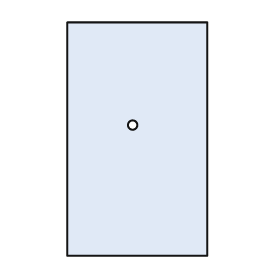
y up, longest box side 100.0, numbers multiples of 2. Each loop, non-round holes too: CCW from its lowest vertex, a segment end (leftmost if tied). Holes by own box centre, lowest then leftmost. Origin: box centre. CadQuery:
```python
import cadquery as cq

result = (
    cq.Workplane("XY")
    .moveTo(-30.0, -50.0)
    .lineTo(30.0, -50.0)
    .lineTo(30.0, 50.0)
    .lineTo(-30.0, 50.0)
    .close()
    .moveTo(-2.0, 6.0)
    .circle(2.0)
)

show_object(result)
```